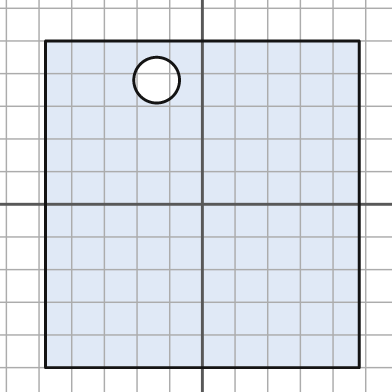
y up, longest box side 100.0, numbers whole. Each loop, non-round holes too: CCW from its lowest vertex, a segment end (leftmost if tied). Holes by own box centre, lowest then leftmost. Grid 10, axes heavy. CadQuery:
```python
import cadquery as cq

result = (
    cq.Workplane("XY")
    .moveTo(-48.0, -50.0)
    .lineTo(48.0, -50.0)
    .lineTo(48.0, 50.0)
    .lineTo(-48.0, 50.0)
    .close()
    .moveTo(-14.0, 38.0)
    .circle(7.0)
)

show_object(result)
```